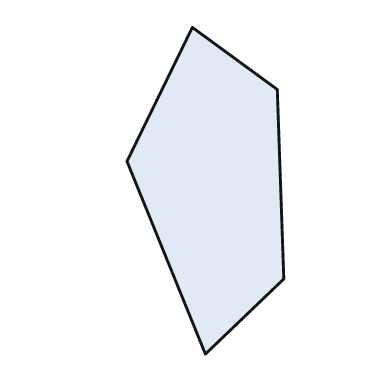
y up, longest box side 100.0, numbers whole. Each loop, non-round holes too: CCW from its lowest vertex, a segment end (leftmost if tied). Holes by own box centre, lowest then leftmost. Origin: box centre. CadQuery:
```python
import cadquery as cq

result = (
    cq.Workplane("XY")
    .moveTo(0.0, -50.0)
    .lineTo(24.0, -27.0)
    .lineTo(22.0, 31.0)
    .lineTo(-4.0, 50.0)
    .lineTo(-24.0, 9.0)
    .close()
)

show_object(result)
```